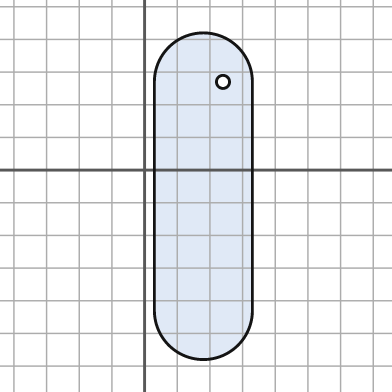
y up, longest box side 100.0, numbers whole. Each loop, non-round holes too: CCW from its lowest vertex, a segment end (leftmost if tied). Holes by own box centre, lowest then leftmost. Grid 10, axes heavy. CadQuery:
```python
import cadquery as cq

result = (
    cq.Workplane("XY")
    .moveTo(3.0, -43.0)
    .threePointArc((18.0, -58.0), (33.0, -43.0))
    .lineTo(33.0, 27.0)
    .threePointArc((18.0, 42.0), (3.0, 27.0))
    .close()
    .moveTo(24.0, 27.0)
    .circle(2.0)
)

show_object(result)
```